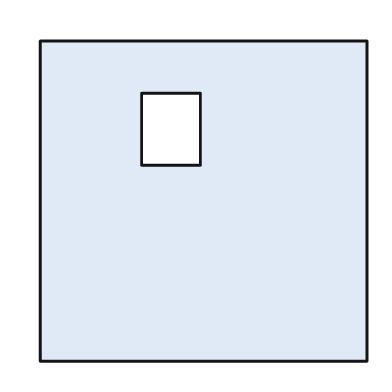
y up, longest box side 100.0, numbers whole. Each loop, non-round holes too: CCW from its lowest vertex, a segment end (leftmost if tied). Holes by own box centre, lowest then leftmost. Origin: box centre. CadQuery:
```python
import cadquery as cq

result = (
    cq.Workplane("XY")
    .moveTo(-50.0, -49.0)
    .lineTo(50.0, -49.0)
    .lineTo(50.0, 49.0)
    .lineTo(-50.0, 49.0)
    .close()
    .moveTo(-19.0, 11.0)
    .lineTo(-1.0, 11.0)
    .lineTo(-1.0, 33.0)
    .lineTo(-19.0, 33.0)
    .close()
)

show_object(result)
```